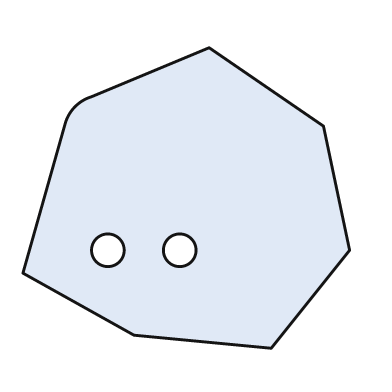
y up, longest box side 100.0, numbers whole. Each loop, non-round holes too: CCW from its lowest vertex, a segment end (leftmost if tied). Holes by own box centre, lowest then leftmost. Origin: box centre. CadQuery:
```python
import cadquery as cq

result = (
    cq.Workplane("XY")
    .moveTo(26.0, -46.0)
    .lineTo(50.0, -16.0)
    .lineTo(42.0, 22.0)
    .lineTo(7.0, 46.0)
    .lineTo(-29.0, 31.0)
    .threePointArc((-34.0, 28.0), (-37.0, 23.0))
    .lineTo(-50.0, -23.0)
    .lineTo(-16.0, -42.0)
    .close()
    .moveTo(-24.0, -16.0)
    .circle(5.0)
    .moveTo(-2.0, -16.0)
    .circle(5.0)
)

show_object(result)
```